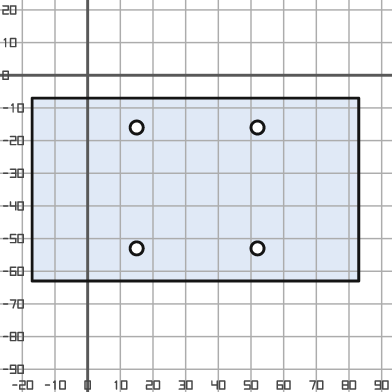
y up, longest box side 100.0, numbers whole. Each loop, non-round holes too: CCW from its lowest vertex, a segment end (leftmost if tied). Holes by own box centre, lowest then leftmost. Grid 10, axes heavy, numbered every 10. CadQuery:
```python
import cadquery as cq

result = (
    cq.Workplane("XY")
    .moveTo(-17.0, -63.0)
    .lineTo(83.0, -63.0)
    .lineTo(83.0, -7.0)
    .lineTo(-17.0, -7.0)
    .close()
    .moveTo(15.0, -53.0)
    .circle(2.0)
    .moveTo(52.0, -53.0)
    .circle(2.0)
    .moveTo(15.0, -16.0)
    .circle(2.0)
    .moveTo(52.0, -16.0)
    .circle(2.0)
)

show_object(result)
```